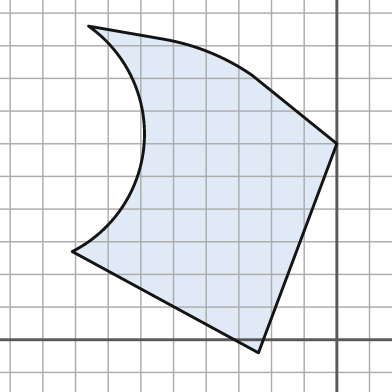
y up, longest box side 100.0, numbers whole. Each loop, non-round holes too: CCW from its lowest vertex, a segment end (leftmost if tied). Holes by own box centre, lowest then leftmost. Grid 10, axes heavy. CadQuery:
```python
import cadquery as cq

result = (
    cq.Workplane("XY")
    .moveTo(-24.0, -4.0)
    .lineTo(0.0, 60.0)
    .lineTo(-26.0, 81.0)
    .threePointArc((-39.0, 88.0), (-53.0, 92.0))
    .lineTo(-76.0, 96.0)
    .threePointArc((-59.0, 60.0), (-81.0, 27.0))
    .close()
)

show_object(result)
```